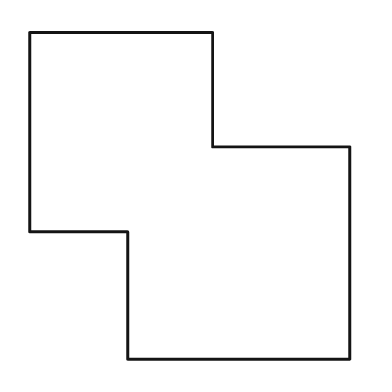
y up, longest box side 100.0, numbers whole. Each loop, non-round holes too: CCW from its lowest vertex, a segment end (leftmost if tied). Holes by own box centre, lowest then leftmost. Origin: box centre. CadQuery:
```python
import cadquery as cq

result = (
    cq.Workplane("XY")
    .moveTo(-19.0, -50.0)
    .lineTo(49.0, -50.0)
    .lineTo(49.0, 15.0)
    .lineTo(7.0, 15.0)
    .lineTo(7.0, 50.0)
    .lineTo(-49.0, 50.0)
    .lineTo(-49.0, -11.0)
    .lineTo(-19.0, -11.0)
    .close()
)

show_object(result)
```